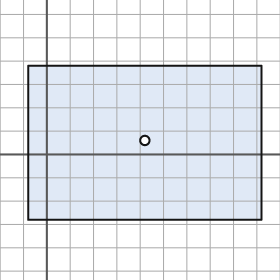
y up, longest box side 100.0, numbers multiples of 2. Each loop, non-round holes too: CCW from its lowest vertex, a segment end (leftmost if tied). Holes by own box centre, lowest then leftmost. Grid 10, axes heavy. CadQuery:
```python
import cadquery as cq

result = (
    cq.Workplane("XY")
    .moveTo(-8.0, -28.0)
    .lineTo(92.0, -28.0)
    .lineTo(92.0, 38.0)
    .lineTo(-8.0, 38.0)
    .close()
    .moveTo(42.0, 6.0)
    .circle(2.0)
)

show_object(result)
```